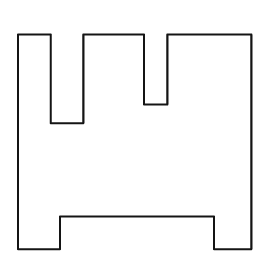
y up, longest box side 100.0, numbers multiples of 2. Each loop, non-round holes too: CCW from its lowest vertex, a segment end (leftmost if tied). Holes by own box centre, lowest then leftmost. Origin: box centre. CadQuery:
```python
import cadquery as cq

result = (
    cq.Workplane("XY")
    .moveTo(-50.0, -46.0)
    .lineTo(-32.0, -46.0)
    .lineTo(-32.0, -32.0)
    .lineTo(34.0, -32.0)
    .lineTo(34.0, -46.0)
    .lineTo(50.0, -46.0)
    .lineTo(50.0, 46.0)
    .lineTo(14.0, 46.0)
    .lineTo(14.0, 16.0)
    .lineTo(4.0, 16.0)
    .lineTo(4.0, 46.0)
    .lineTo(-22.0, 46.0)
    .lineTo(-22.0, 8.0)
    .lineTo(-36.0, 8.0)
    .lineTo(-36.0, 46.0)
    .lineTo(-50.0, 46.0)
    .close()
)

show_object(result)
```